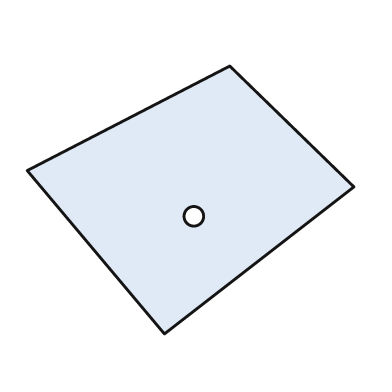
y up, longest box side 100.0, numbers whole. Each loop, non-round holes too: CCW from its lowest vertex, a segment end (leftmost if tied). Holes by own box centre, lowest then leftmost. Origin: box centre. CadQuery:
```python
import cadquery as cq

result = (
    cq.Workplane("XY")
    .moveTo(-8.0, -41.0)
    .lineTo(50.0, 4.0)
    .lineTo(12.0, 41.0)
    .lineTo(-50.0, 9.0)
    .close()
    .moveTo(1.0, -5.0)
    .circle(3.0)
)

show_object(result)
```